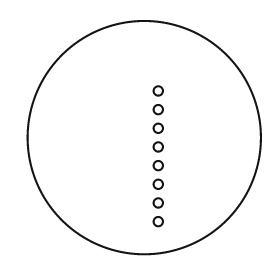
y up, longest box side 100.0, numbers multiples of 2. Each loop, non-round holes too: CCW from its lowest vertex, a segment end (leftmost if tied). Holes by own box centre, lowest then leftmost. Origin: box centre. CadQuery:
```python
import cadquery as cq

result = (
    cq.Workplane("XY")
    .moveTo(0.0, 0.0)
    .circle(50.0)
    .moveTo(6.0, -36.0)
    .circle(2.0)
    .moveTo(6.0, -28.0)
    .circle(2.0)
    .moveTo(6.0, -20.0)
    .circle(2.0)
    .moveTo(6.0, -12.0)
    .circle(2.0)
    .moveTo(6.0, -4.0)
    .circle(2.0)
    .moveTo(6.0, 4.0)
    .circle(2.0)
    .moveTo(6.0, 12.0)
    .circle(2.0)
    .moveTo(6.0, 20.0)
    .circle(2.0)
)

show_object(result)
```